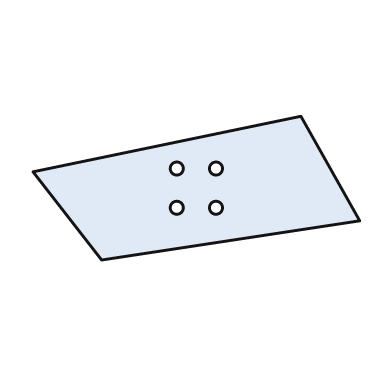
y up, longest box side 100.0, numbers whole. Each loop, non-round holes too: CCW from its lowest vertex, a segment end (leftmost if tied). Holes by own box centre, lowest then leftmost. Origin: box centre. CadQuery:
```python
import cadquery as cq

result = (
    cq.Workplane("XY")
    .moveTo(-29.0, -22.0)
    .lineTo(50.0, -10.0)
    .lineTo(32.0, 22.0)
    .lineTo(-50.0, 5.0)
    .close()
    .moveTo(-6.0, -6.0)
    .circle(2.0)
    .moveTo(6.0, -6.0)
    .circle(2.0)
    .moveTo(-6.0, 6.0)
    .circle(2.0)
    .moveTo(6.0, 6.0)
    .circle(2.0)
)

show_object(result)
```